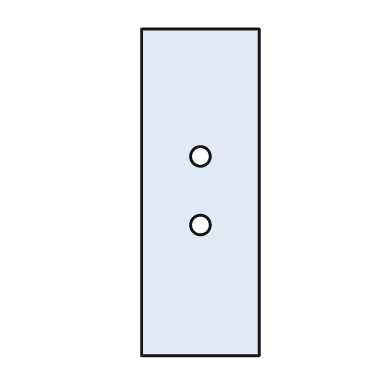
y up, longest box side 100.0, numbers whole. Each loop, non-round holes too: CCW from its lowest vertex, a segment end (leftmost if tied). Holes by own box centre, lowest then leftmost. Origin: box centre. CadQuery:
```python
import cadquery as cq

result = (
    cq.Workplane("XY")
    .moveTo(-18.0, -50.0)
    .lineTo(18.0, -50.0)
    .lineTo(18.0, 50.0)
    .lineTo(-18.0, 50.0)
    .close()
    .moveTo(0.0, -10.0)
    .circle(3.0)
    .moveTo(0.0, 11.0)
    .circle(3.0)
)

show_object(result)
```